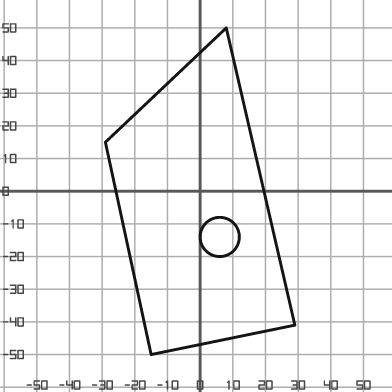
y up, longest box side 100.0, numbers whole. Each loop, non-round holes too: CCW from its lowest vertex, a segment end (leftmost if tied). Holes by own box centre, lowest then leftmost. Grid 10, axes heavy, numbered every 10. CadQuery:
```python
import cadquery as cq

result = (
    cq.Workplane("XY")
    .moveTo(-15.0, -50.0)
    .lineTo(29.0, -41.0)
    .lineTo(8.0, 50.0)
    .lineTo(-29.0, 15.0)
    .close()
    .moveTo(6.0, -14.0)
    .circle(6.0)
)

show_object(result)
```